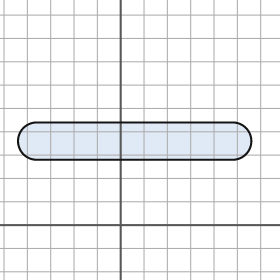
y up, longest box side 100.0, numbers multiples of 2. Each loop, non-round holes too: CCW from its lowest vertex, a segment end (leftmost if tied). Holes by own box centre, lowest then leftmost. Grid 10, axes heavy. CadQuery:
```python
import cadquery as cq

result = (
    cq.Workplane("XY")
    .moveTo(-36.0, 28.0)
    .lineTo(48.0, 28.0)
    .threePointArc((56.0, 36.0), (48.0, 44.0))
    .lineTo(-36.0, 44.0)
    .threePointArc((-44.0, 36.0), (-36.0, 28.0))
    .close()
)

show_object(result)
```